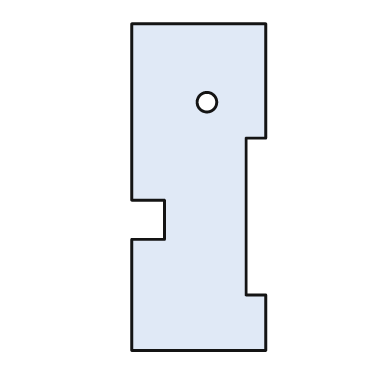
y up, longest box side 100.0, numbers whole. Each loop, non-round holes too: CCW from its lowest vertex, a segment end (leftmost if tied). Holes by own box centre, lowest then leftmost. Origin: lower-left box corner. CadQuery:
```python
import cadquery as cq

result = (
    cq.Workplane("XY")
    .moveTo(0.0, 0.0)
    .lineTo(41.0, 0.0)
    .lineTo(41.0, 17.0)
    .lineTo(35.0, 17.0)
    .lineTo(35.0, 65.0)
    .lineTo(41.0, 65.0)
    .lineTo(41.0, 100.0)
    .lineTo(0.0, 100.0)
    .lineTo(0.0, 46.0)
    .lineTo(10.0, 46.0)
    .lineTo(10.0, 34.0)
    .lineTo(0.0, 34.0)
    .close()
    .moveTo(23.0, 76.0)
    .circle(3.0)
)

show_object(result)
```